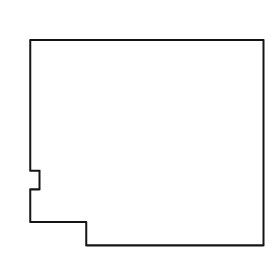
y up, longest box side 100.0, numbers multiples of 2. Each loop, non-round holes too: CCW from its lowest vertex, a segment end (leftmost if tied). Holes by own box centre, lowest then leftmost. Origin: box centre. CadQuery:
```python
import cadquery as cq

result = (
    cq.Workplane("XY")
    .moveTo(-26.0, -44.0)
    .lineTo(50.0, -44.0)
    .lineTo(50.0, 44.0)
    .lineTo(-50.0, 44.0)
    .lineTo(-50.0, -12.0)
    .lineTo(-46.0, -12.0)
    .lineTo(-46.0, -20.0)
    .lineTo(-50.0, -20.0)
    .lineTo(-50.0, -34.0)
    .lineTo(-26.0, -34.0)
    .close()
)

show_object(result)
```